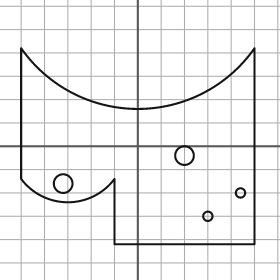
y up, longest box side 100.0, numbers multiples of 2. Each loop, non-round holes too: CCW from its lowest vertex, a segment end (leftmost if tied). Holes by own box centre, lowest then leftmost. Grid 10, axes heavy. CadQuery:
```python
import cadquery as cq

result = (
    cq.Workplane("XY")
    .moveTo(-10.0, -42.0)
    .lineTo(50.0, -42.0)
    .lineTo(50.0, 42.0)
    .threePointArc((0.0, 16.0), (-50.0, 42.0))
    .lineTo(-50.0, -14.0)
    .threePointArc((-30.0, -24.0), (-10.0, -14.0))
    .close()
    .moveTo(30.0, -30.0)
    .circle(2.0)
    .moveTo(44.0, -20.0)
    .circle(2.0)
    .moveTo(-32.0, -16.0)
    .circle(4.0)
    .moveTo(20.0, -4.0)
    .circle(4.0)
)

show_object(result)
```